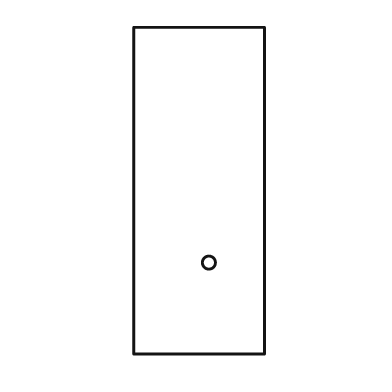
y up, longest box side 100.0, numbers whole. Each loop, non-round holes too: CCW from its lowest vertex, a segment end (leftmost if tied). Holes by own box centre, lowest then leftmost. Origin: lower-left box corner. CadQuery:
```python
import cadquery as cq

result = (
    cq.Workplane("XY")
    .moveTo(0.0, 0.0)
    .lineTo(40.0, 0.0)
    .lineTo(40.0, 100.0)
    .lineTo(0.0, 100.0)
    .close()
    .moveTo(23.0, 28.0)
    .circle(2.0)
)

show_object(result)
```